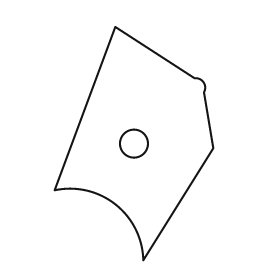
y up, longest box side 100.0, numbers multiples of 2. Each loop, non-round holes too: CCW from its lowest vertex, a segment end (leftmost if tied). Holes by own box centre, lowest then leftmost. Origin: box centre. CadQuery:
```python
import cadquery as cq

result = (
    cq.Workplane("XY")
    .moveTo(4.0, -50.0)
    .lineTo(34.0, -2.0)
    .lineTo(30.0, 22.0)
    .threePointArc((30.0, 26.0), (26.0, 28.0))
    .lineTo(-8.0, 50.0)
    .lineTo(-34.0, -20.0)
    .threePointArc((-8.0, -26.0), (4.0, -50.0))
    .close()
    .moveTo(0.0, 0.0)
    .circle(6.0)
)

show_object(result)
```